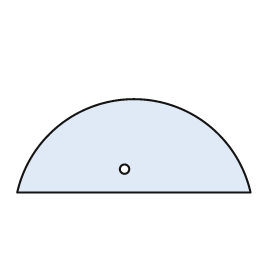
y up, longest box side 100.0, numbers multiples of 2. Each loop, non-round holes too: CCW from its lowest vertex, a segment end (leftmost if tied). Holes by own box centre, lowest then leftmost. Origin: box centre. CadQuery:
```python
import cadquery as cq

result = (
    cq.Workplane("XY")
    .moveTo(-50.0, -20.0)
    .lineTo(50.0, -20.0)
    .threePointArc((0.0, 20.0), (-50.0, -20.0))
    .close()
    .moveTo(-4.0, -10.0)
    .circle(2.0)
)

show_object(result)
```